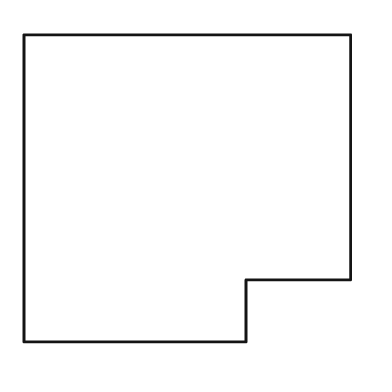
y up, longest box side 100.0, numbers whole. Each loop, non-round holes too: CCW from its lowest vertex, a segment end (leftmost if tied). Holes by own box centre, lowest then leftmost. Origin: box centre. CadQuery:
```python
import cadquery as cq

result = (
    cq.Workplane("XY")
    .moveTo(-50.0, -47.0)
    .lineTo(18.0, -47.0)
    .lineTo(18.0, -28.0)
    .lineTo(50.0, -28.0)
    .lineTo(50.0, 47.0)
    .lineTo(-50.0, 47.0)
    .close()
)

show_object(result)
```